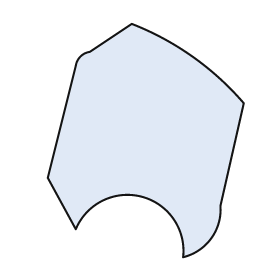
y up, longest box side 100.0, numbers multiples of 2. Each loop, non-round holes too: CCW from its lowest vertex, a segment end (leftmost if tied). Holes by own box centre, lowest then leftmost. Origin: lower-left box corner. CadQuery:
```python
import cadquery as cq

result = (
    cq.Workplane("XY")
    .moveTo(58.0, 0.0)
    .threePointArc((70.0, 8.0), (74.0, 22.0))
    .lineTo(84.0, 66.0)
    .threePointArc((62.0, 86.0), (36.0, 100.0))
    .lineTo(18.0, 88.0)
    .threePointArc((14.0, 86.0), (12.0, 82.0))
    .lineTo(0.0, 34.0)
    .lineTo(12.0, 12.0)
    .threePointArc((40.0, 26.0), (58.0, 0.0))
    .close()
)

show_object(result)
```